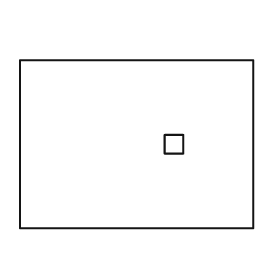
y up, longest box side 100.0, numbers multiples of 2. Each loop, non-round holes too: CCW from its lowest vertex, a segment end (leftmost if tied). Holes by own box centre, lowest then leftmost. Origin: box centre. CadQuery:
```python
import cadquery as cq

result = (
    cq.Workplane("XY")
    .moveTo(-50.0, -36.0)
    .lineTo(50.0, -36.0)
    .lineTo(50.0, 36.0)
    .lineTo(-50.0, 36.0)
    .close()
    .moveTo(12.0, -4.0)
    .lineTo(20.0, -4.0)
    .lineTo(20.0, 4.0)
    .lineTo(12.0, 4.0)
    .close()
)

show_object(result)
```